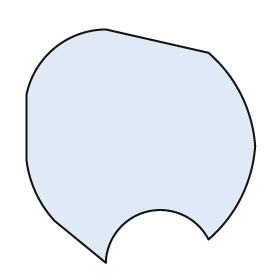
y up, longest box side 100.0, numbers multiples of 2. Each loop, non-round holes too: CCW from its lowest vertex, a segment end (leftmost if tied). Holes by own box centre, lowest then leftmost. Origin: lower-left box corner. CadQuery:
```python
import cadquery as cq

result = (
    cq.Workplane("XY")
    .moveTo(34.0, 0.0)
    .threePointArc((52.0, 22.0), (78.0, 10.0))
    .threePointArc((92.0, 28.0), (98.0, 50.0))
    .threePointArc((92.0, 72.0), (78.0, 90.0))
    .lineTo(34.0, 100.0)
    .threePointArc((12.0, 92.0), (0.0, 72.0))
    .lineTo(0.0, 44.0)
    .threePointArc((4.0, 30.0), (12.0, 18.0))
    .close()
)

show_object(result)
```